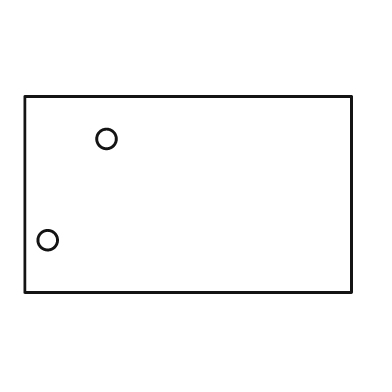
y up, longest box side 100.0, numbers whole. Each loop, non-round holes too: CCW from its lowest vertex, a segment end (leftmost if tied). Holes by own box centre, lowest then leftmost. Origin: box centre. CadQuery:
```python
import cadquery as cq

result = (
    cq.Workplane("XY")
    .moveTo(-50.0, -30.0)
    .lineTo(50.0, -30.0)
    .lineTo(50.0, 30.0)
    .lineTo(-50.0, 30.0)
    .close()
    .moveTo(-43.0, -14.0)
    .circle(3.0)
    .moveTo(-25.0, 17.0)
    .circle(3.0)
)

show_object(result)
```